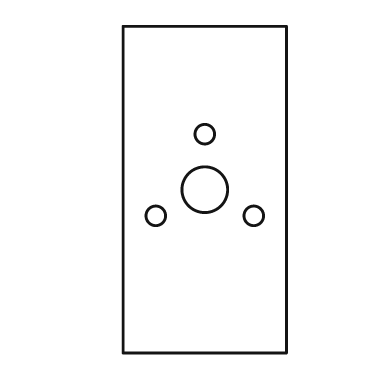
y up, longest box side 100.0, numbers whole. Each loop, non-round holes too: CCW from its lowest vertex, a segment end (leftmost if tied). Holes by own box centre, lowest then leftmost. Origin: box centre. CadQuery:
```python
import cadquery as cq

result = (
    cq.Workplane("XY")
    .moveTo(-25.0, -50.0)
    .lineTo(25.0, -50.0)
    .lineTo(25.0, 50.0)
    .lineTo(-25.0, 50.0)
    .close()
    .moveTo(-15.0, -8.0)
    .circle(3.0)
    .moveTo(15.0, -8.0)
    .circle(3.0)
    .moveTo(0.0, 0.0)
    .circle(7.0)
    .moveTo(0.0, 17.0)
    .circle(3.0)
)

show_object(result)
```